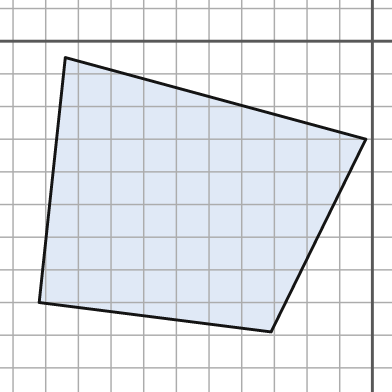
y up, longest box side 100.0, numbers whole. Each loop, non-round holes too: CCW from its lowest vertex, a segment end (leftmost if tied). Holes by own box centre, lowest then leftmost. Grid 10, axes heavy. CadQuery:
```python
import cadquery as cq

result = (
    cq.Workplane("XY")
    .moveTo(-31.0, -89.0)
    .lineTo(-2.0, -30.0)
    .lineTo(-94.0, -5.0)
    .lineTo(-102.0, -80.0)
    .close()
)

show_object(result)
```